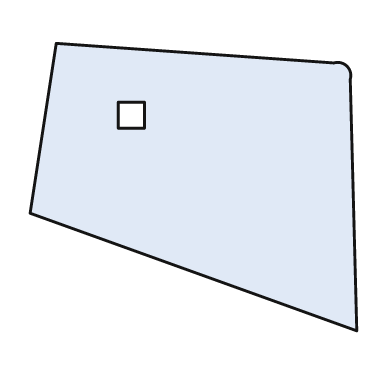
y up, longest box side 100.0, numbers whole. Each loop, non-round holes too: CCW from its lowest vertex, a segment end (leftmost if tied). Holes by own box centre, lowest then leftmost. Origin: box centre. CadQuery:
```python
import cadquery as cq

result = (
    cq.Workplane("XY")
    .moveTo(50.0, -44.0)
    .lineTo(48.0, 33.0)
    .threePointArc((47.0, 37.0), (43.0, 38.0))
    .lineTo(-42.0, 44.0)
    .lineTo(-50.0, -8.0)
    .close()
    .moveTo(-23.0, 18.0)
    .lineTo(-15.0, 18.0)
    .lineTo(-15.0, 26.0)
    .lineTo(-23.0, 26.0)
    .close()
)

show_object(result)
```